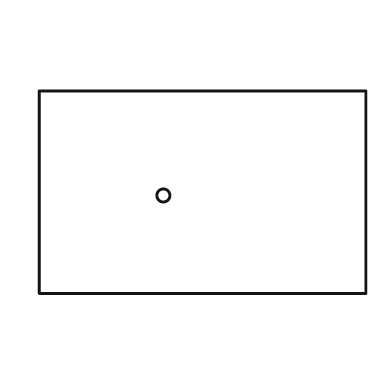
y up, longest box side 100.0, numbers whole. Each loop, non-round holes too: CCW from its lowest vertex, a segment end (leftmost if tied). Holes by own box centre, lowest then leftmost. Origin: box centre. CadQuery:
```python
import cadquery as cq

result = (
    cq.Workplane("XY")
    .moveTo(-50.0, -31.0)
    .lineTo(50.0, -31.0)
    .lineTo(50.0, 31.0)
    .lineTo(-50.0, 31.0)
    .close()
    .moveTo(-12.0, -1.0)
    .circle(2.0)
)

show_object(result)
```